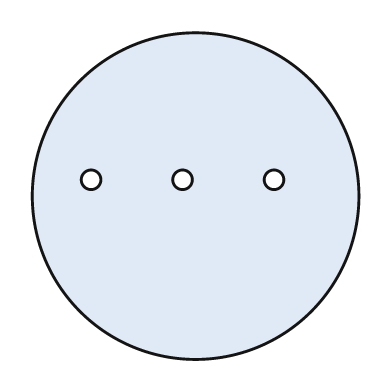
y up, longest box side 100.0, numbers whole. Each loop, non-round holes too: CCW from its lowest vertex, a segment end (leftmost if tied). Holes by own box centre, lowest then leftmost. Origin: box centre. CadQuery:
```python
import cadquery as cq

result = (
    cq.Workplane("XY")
    .moveTo(0.0, 0.0)
    .circle(50.0)
    .moveTo(-32.0, 5.0)
    .circle(3.0)
    .moveTo(-4.0, 5.0)
    .circle(3.0)
    .moveTo(24.0, 5.0)
    .circle(3.0)
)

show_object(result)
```